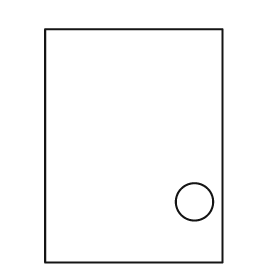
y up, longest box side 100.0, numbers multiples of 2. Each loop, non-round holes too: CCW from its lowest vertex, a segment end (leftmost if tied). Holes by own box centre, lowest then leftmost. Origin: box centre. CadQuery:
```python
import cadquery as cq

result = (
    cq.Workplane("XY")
    .moveTo(-38.0, -50.0)
    .lineTo(38.0, -50.0)
    .lineTo(38.0, 50.0)
    .lineTo(-38.0, 50.0)
    .close()
    .moveTo(26.0, -24.0)
    .circle(8.0)
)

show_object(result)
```